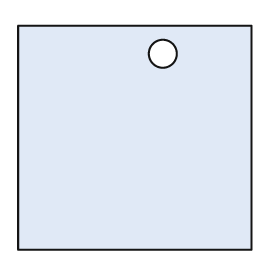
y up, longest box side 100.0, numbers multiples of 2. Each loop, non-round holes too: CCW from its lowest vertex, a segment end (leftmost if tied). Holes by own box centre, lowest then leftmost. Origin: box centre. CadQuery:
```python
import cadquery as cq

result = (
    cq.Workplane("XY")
    .moveTo(-50.0, -48.0)
    .lineTo(50.0, -48.0)
    .lineTo(50.0, 48.0)
    .lineTo(-50.0, 48.0)
    .close()
    .moveTo(12.0, 36.0)
    .circle(6.0)
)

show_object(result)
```